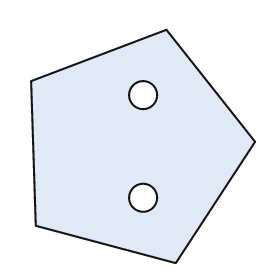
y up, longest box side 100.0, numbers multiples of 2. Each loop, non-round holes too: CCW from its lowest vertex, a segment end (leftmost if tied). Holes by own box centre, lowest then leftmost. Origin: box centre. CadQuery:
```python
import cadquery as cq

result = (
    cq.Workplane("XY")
    .moveTo(14.0, -50.0)
    .lineTo(48.0, 2.0)
    .lineTo(10.0, 50.0)
    .lineTo(-48.0, 28.0)
    .lineTo(-46.0, -34.0)
    .close()
    .moveTo(0.0, -22.0)
    .circle(6.0)
    .moveTo(0.0, 22.0)
    .circle(6.0)
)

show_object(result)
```